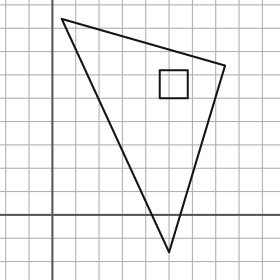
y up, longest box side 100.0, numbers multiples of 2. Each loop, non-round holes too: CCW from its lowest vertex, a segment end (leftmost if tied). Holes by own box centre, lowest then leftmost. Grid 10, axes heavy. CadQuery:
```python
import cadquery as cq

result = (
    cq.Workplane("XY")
    .moveTo(50.0, -16.0)
    .lineTo(74.0, 64.0)
    .lineTo(4.0, 84.0)
    .close()
    .moveTo(46.0, 50.0)
    .lineTo(58.0, 50.0)
    .lineTo(58.0, 62.0)
    .lineTo(46.0, 62.0)
    .close()
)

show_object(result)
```